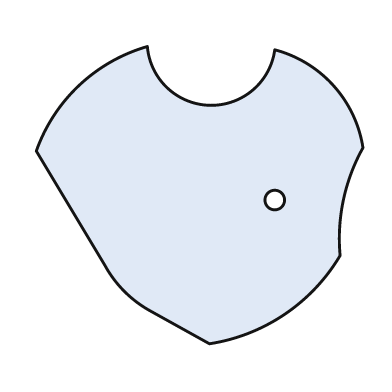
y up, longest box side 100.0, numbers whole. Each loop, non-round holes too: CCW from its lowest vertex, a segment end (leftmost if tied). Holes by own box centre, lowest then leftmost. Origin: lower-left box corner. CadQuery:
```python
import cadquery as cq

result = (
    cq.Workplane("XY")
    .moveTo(53.0, 0.0)
    .threePointArc((76.0, 9.0), (93.0, 27.0))
    .threePointArc((94.0, 44.0), (100.0, 60.0))
    .threePointArc((91.0, 79.0), (73.0, 90.0))
    .threePointArc((53.0, 73.0), (34.0, 91.0))
    .threePointArc((13.0, 79.0), (0.0, 59.0))
    .lineTo(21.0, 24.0)
    .threePointArc((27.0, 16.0), (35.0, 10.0))
    .close()
    .moveTo(73.0, 44.0)
    .circle(3.0)
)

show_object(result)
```